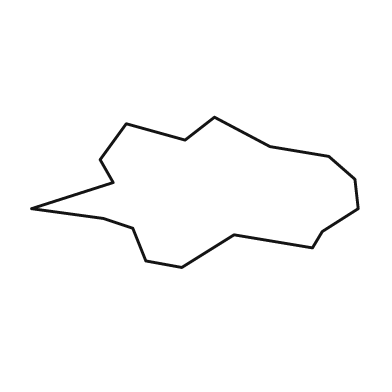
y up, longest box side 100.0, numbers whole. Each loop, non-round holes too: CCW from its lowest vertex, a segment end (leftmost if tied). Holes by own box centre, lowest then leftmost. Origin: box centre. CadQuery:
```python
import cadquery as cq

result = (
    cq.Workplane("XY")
    .moveTo(-4.0, -23.0)
    .lineTo(12.0, -13.0)
    .lineTo(36.0, -17.0)
    .lineTo(39.0, -12.0)
    .lineTo(50.0, -5.0)
    .lineTo(49.0, 4.0)
    .lineTo(41.0, 11.0)
    .lineTo(23.0, 14.0)
    .lineTo(6.0, 23.0)
    .lineTo(-3.0, 16.0)
    .lineTo(-21.0, 21.0)
    .lineTo(-29.0, 10.0)
    .lineTo(-25.0, 3.0)
    .lineTo(-50.0, -5.0)
    .lineTo(-28.0, -8.0)
    .lineTo(-19.0, -11.0)
    .lineTo(-15.0, -21.0)
    .close()
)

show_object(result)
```